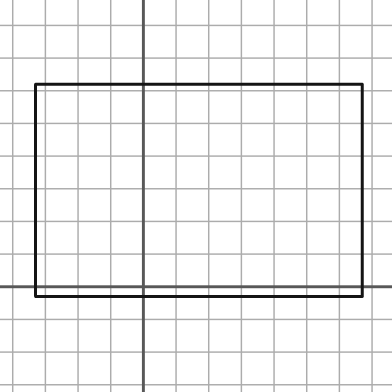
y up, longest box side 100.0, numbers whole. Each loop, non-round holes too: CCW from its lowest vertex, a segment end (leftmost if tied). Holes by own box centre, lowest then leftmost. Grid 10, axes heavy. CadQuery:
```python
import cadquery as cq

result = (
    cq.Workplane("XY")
    .moveTo(-33.0, -3.0)
    .lineTo(67.0, -3.0)
    .lineTo(67.0, 62.0)
    .lineTo(-33.0, 62.0)
    .close()
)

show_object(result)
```